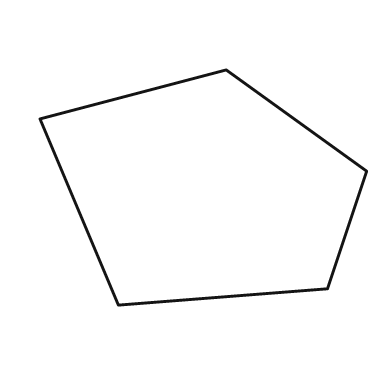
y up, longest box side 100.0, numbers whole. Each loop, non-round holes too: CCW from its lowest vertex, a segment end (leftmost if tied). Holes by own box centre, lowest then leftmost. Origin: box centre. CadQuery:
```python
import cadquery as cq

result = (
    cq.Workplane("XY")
    .moveTo(-26.0, -36.0)
    .lineTo(38.0, -31.0)
    .lineTo(50.0, 5.0)
    .lineTo(7.0, 36.0)
    .lineTo(-50.0, 21.0)
    .close()
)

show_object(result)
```